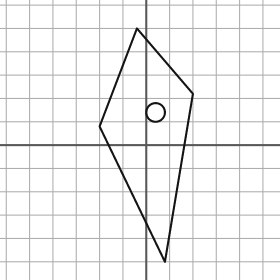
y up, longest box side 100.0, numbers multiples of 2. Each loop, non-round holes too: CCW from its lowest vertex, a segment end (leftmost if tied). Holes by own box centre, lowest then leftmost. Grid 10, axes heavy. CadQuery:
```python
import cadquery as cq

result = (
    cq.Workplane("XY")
    .moveTo(8.0, -50.0)
    .lineTo(20.0, 22.0)
    .lineTo(-4.0, 50.0)
    .lineTo(-20.0, 8.0)
    .close()
    .moveTo(4.0, 14.0)
    .circle(4.0)
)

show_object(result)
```